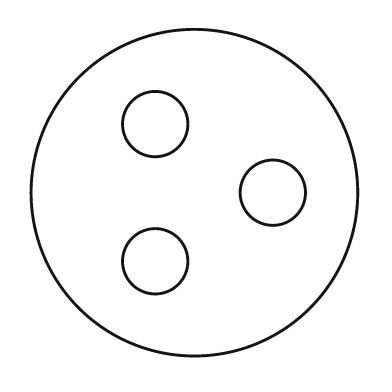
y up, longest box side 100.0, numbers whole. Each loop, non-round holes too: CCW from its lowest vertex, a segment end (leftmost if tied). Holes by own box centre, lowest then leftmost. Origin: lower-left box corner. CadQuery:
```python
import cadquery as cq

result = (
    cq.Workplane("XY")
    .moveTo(50.0, 50.0)
    .circle(50.0)
    .moveTo(38.0, 29.0)
    .circle(10.0)
    .moveTo(74.0, 50.0)
    .circle(10.0)
    .moveTo(38.0, 71.0)
    .circle(10.0)
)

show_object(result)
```